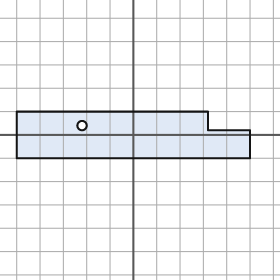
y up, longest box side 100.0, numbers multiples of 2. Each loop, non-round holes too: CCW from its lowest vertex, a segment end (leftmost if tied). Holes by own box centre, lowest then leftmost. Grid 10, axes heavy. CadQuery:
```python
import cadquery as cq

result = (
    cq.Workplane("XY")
    .moveTo(-50.0, -10.0)
    .lineTo(50.0, -10.0)
    .lineTo(50.0, 2.0)
    .lineTo(32.0, 2.0)
    .lineTo(32.0, 10.0)
    .lineTo(-50.0, 10.0)
    .close()
    .moveTo(-22.0, 4.0)
    .circle(2.0)
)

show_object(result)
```